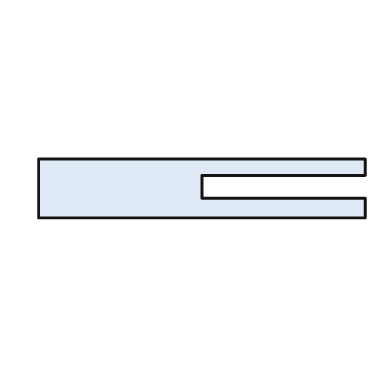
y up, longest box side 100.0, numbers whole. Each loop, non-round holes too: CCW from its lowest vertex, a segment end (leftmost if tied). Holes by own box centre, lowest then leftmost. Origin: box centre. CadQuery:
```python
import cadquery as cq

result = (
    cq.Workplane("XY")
    .moveTo(-50.0, -9.0)
    .lineTo(50.0, -9.0)
    .lineTo(50.0, -3.0)
    .lineTo(0.0, -3.0)
    .lineTo(0.0, 4.0)
    .lineTo(50.0, 4.0)
    .lineTo(50.0, 9.0)
    .lineTo(-50.0, 9.0)
    .close()
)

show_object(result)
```